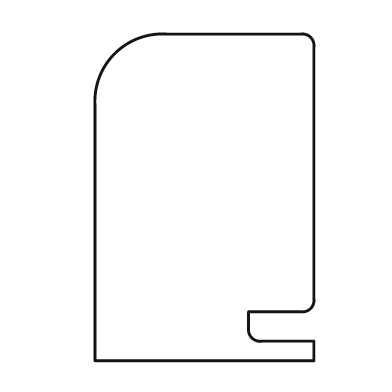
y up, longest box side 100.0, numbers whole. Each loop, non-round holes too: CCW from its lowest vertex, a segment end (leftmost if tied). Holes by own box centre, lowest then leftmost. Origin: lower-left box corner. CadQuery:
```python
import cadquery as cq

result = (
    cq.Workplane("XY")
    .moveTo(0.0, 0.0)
    .lineTo(67.0, 0.0)
    .lineTo(67.0, 6.0)
    .lineTo(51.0, 6.0)
    .threePointArc((48.0, 7.0), (47.0, 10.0))
    .lineTo(47.0, 15.0)
    .lineTo(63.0, 15.0)
    .threePointArc((66.0, 16.0), (67.0, 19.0))
    .lineTo(67.0, 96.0)
    .threePointArc((66.0, 99.0), (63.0, 100.0))
    .lineTo(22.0, 100.0)
    .threePointArc((6.0, 94.0), (0.0, 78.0))
    .close()
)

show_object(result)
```